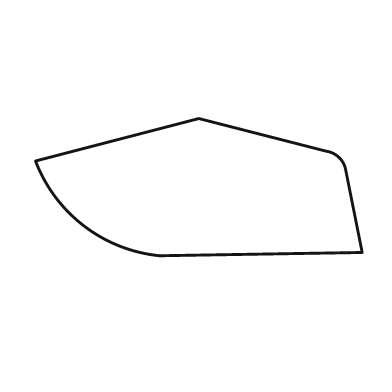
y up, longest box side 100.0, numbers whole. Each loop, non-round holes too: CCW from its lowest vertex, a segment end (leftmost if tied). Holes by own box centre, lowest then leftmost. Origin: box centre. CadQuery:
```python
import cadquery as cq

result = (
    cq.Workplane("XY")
    .moveTo(-12.0, -21.0)
    .lineTo(50.0, -20.0)
    .lineTo(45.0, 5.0)
    .threePointArc((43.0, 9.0), (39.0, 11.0))
    .lineTo(0.0, 21.0)
    .lineTo(-50.0, 8.0)
    .threePointArc((-35.0, -12.0), (-12.0, -21.0))
    .close()
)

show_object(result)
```